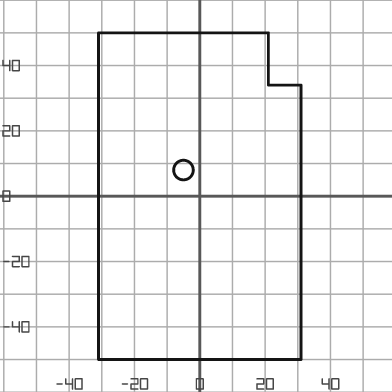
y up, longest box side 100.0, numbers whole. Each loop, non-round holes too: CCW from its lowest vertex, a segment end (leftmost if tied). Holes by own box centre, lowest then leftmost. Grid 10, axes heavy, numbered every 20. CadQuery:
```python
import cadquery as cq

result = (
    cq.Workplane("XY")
    .moveTo(-31.0, -50.0)
    .lineTo(31.0, -50.0)
    .lineTo(31.0, 34.0)
    .lineTo(21.0, 34.0)
    .lineTo(21.0, 50.0)
    .lineTo(-31.0, 50.0)
    .close()
    .moveTo(-5.0, 8.0)
    .circle(3.0)
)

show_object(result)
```